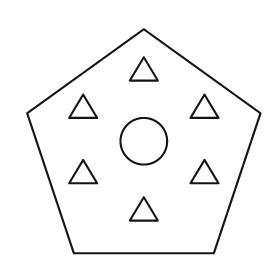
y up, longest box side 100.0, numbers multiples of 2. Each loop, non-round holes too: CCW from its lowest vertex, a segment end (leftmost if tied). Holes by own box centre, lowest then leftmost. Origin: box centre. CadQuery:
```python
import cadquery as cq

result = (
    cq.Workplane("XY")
    .moveTo(-30.0, -48.0)
    .lineTo(30.0, -48.0)
    .lineTo(50.0, 12.0)
    .lineTo(0.0, 48.0)
    .lineTo(-50.0, 12.0)
    .close()
    .moveTo(-6.0, -34.0)
    .lineTo(6.0, -34.0)
    .lineTo(0.0, -24.0)
    .close()
    .moveTo(-32.0, -18.0)
    .lineTo(-20.0, -18.0)
    .lineTo(-26.0, -8.0)
    .close()
    .moveTo(20.0, -18.0)
    .lineTo(32.0, -18.0)
    .lineTo(26.0, -8.0)
    .close()
    .moveTo(0.0, 0.0)
    .circle(10.0)
    .moveTo(-32.0, 10.0)
    .lineTo(-20.0, 10.0)
    .lineTo(-26.0, 20.0)
    .close()
    .moveTo(20.0, 10.0)
    .lineTo(32.0, 10.0)
    .lineTo(26.0, 20.0)
    .close()
    .moveTo(-6.0, 26.0)
    .lineTo(6.0, 26.0)
    .lineTo(0.0, 36.0)
    .close()
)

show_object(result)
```